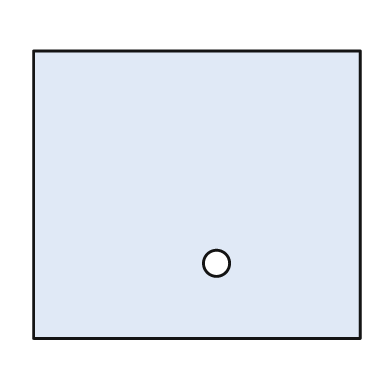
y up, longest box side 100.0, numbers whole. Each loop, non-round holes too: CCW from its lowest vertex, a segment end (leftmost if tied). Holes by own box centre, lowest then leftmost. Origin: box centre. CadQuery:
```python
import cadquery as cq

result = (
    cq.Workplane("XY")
    .moveTo(-50.0, -44.0)
    .lineTo(50.0, -44.0)
    .lineTo(50.0, 44.0)
    .lineTo(-50.0, 44.0)
    .close()
    .moveTo(6.0, -21.0)
    .circle(4.0)
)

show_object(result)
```